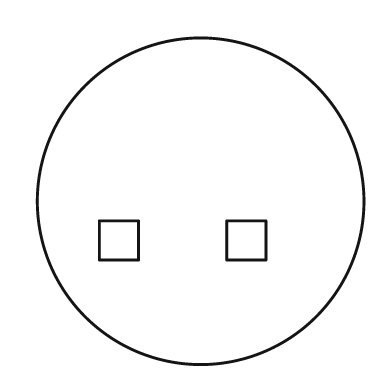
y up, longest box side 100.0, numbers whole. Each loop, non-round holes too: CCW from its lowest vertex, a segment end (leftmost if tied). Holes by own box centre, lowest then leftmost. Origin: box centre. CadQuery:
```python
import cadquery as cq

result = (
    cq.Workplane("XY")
    .moveTo(0.0, 0.0)
    .circle(50.0)
    .moveTo(-31.0, -18.0)
    .lineTo(-19.0, -18.0)
    .lineTo(-19.0, -6.0)
    .lineTo(-31.0, -6.0)
    .close()
    .moveTo(8.0, -18.0)
    .lineTo(20.0, -18.0)
    .lineTo(20.0, -6.0)
    .lineTo(8.0, -6.0)
    .close()
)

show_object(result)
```